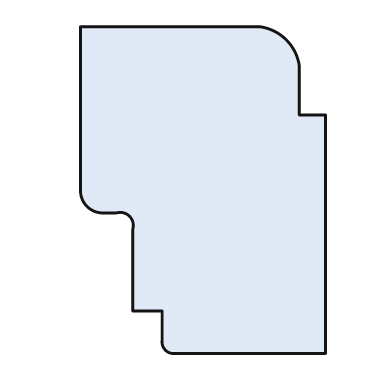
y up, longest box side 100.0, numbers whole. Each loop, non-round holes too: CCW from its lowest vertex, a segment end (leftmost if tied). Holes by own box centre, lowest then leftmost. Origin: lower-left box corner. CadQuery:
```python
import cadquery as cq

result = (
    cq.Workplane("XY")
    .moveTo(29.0, 0.0)
    .lineTo(75.0, 0.0)
    .lineTo(75.0, 73.0)
    .lineTo(67.0, 73.0)
    .lineTo(67.0, 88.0)
    .threePointArc((63.0, 96.0), (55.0, 100.0))
    .lineTo(0.0, 100.0)
    .lineTo(0.0, 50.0)
    .threePointArc((2.0, 45.0), (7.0, 43.0))
    .lineTo(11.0, 43.0)
    .threePointArc((15.0, 42.0), (16.0, 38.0))
    .lineTo(16.0, 13.0)
    .lineTo(25.0, 13.0)
    .lineTo(25.0, 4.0)
    .threePointArc((26.0, 1.0), (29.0, 0.0))
    .close()
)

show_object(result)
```